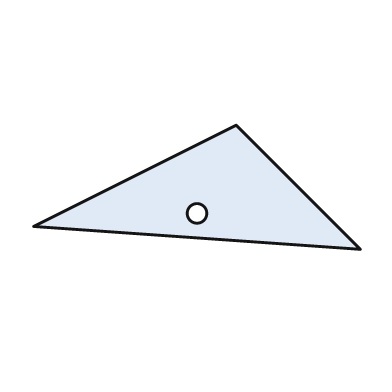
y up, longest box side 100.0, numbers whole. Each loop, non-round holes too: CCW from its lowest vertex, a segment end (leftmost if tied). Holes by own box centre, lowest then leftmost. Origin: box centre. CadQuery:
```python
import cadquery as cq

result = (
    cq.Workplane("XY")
    .moveTo(50.0, -19.0)
    .lineTo(12.0, 19.0)
    .lineTo(-50.0, -12.0)
    .close()
    .moveTo(0.0, -8.0)
    .circle(3.0)
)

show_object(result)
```